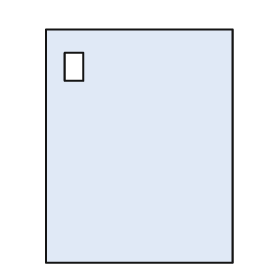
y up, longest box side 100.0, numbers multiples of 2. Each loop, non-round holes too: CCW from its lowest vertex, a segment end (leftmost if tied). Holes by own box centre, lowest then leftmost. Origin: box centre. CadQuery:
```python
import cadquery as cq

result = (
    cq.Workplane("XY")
    .moveTo(-40.0, -50.0)
    .lineTo(40.0, -50.0)
    .lineTo(40.0, 50.0)
    .lineTo(-40.0, 50.0)
    .close()
    .moveTo(-32.0, 28.0)
    .lineTo(-24.0, 28.0)
    .lineTo(-24.0, 40.0)
    .lineTo(-32.0, 40.0)
    .close()
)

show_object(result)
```